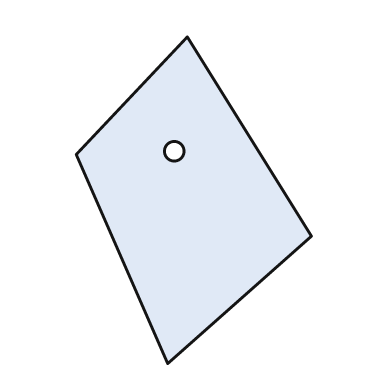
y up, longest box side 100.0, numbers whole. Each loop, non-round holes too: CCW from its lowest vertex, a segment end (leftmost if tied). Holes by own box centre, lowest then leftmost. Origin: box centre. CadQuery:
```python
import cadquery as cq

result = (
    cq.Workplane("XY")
    .moveTo(-8.0, -50.0)
    .lineTo(36.0, -11.0)
    .lineTo(-2.0, 50.0)
    .lineTo(-36.0, 14.0)
    .close()
    .moveTo(-6.0, 15.0)
    .circle(3.0)
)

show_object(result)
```